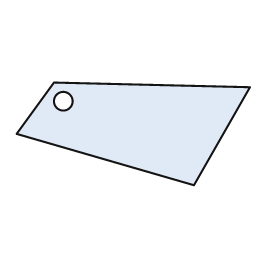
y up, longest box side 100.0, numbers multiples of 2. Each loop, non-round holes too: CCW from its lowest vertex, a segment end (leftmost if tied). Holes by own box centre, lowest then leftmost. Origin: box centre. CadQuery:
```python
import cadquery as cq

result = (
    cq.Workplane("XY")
    .moveTo(26.0, -22.0)
    .lineTo(50.0, 20.0)
    .lineTo(-34.0, 22.0)
    .lineTo(-50.0, 0.0)
    .close()
    .moveTo(-30.0, 14.0)
    .circle(4.0)
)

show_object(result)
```